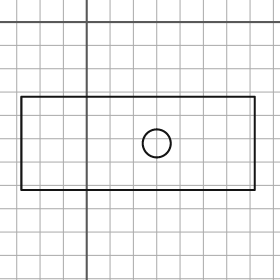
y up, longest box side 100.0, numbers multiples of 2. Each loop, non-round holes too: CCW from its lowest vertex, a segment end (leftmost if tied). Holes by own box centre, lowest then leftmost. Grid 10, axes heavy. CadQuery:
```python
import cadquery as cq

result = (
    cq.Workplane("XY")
    .moveTo(-28.0, -72.0)
    .lineTo(72.0, -72.0)
    .lineTo(72.0, -32.0)
    .lineTo(-28.0, -32.0)
    .close()
    .moveTo(30.0, -52.0)
    .circle(6.0)
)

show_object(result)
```